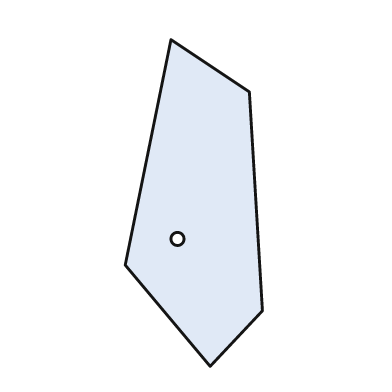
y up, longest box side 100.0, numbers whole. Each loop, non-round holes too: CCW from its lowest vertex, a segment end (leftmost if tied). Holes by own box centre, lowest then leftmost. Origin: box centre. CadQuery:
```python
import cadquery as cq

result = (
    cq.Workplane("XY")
    .moveTo(5.0, -50.0)
    .lineTo(21.0, -33.0)
    .lineTo(17.0, 34.0)
    .lineTo(-7.0, 50.0)
    .lineTo(-21.0, -19.0)
    .close()
    .moveTo(-5.0, -11.0)
    .circle(2.0)
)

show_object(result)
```